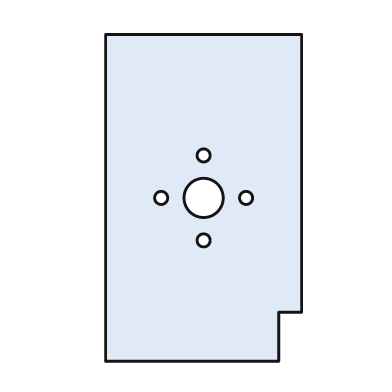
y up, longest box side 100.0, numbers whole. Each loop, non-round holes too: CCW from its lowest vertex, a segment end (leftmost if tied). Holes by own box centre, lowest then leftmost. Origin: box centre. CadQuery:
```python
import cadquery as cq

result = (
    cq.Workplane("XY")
    .moveTo(-30.0, -50.0)
    .lineTo(23.0, -50.0)
    .lineTo(23.0, -35.0)
    .lineTo(30.0, -35.0)
    .lineTo(30.0, 50.0)
    .lineTo(-30.0, 50.0)
    .close()
    .moveTo(0.0, -13.0)
    .circle(2.0)
    .moveTo(-13.0, 0.0)
    .circle(2.0)
    .moveTo(0.0, 0.0)
    .circle(6.0)
    .moveTo(13.0, 0.0)
    .circle(2.0)
    .moveTo(0.0, 13.0)
    .circle(2.0)
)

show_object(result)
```